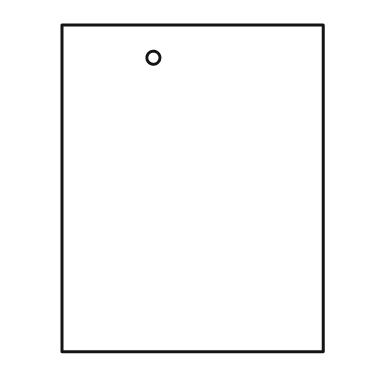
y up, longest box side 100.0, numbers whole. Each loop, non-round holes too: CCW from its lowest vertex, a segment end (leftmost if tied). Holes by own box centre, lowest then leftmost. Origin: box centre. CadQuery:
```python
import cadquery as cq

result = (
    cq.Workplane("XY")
    .moveTo(-40.0, -50.0)
    .lineTo(40.0, -50.0)
    .lineTo(40.0, 50.0)
    .lineTo(-40.0, 50.0)
    .close()
    .moveTo(-12.0, 40.0)
    .circle(2.0)
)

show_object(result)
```